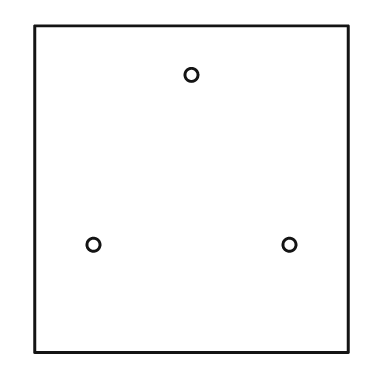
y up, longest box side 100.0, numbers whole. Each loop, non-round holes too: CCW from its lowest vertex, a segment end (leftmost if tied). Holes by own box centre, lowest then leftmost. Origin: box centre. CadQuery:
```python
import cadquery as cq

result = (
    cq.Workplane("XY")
    .moveTo(-48.0, -50.0)
    .lineTo(48.0, -50.0)
    .lineTo(48.0, 50.0)
    .lineTo(-48.0, 50.0)
    .close()
    .moveTo(-30.0, -17.0)
    .circle(2.0)
    .moveTo(30.0, -17.0)
    .circle(2.0)
    .moveTo(0.0, 35.0)
    .circle(2.0)
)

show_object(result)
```